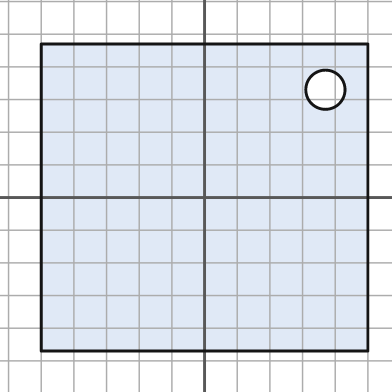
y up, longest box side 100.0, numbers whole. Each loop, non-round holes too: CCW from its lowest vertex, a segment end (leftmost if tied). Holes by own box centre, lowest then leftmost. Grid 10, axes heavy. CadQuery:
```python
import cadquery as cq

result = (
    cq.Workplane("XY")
    .moveTo(-50.0, -47.0)
    .lineTo(50.0, -47.0)
    .lineTo(50.0, 47.0)
    .lineTo(-50.0, 47.0)
    .close()
    .moveTo(37.0, 33.0)
    .circle(6.0)
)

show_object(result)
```